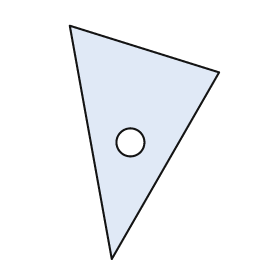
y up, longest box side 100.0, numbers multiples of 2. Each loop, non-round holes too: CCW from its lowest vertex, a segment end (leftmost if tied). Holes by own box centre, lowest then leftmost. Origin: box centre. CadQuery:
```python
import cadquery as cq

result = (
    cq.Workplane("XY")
    .moveTo(-14.0, -50.0)
    .lineTo(32.0, 30.0)
    .lineTo(-32.0, 50.0)
    .close()
    .moveTo(-6.0, 0.0)
    .circle(6.0)
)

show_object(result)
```